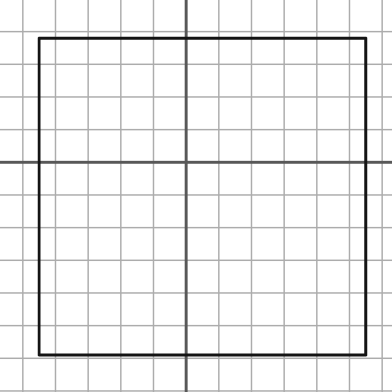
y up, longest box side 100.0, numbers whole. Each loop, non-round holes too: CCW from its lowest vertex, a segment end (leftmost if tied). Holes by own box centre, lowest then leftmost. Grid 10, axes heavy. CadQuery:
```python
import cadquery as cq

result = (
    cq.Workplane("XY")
    .moveTo(-45.0, -59.0)
    .lineTo(55.0, -59.0)
    .lineTo(55.0, 38.0)
    .lineTo(-45.0, 38.0)
    .close()
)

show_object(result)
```